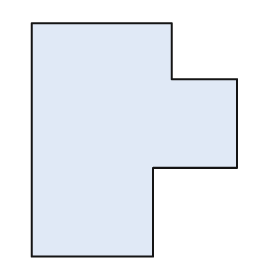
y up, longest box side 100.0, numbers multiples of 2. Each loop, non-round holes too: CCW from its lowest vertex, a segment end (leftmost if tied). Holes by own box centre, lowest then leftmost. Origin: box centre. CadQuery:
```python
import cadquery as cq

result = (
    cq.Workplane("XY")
    .moveTo(-44.0, -50.0)
    .lineTo(8.0, -50.0)
    .lineTo(8.0, -12.0)
    .lineTo(44.0, -12.0)
    .lineTo(44.0, 26.0)
    .lineTo(16.0, 26.0)
    .lineTo(16.0, 50.0)
    .lineTo(-44.0, 50.0)
    .close()
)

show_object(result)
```